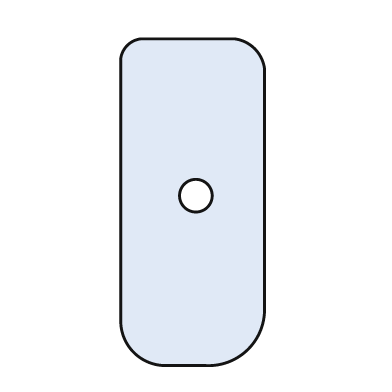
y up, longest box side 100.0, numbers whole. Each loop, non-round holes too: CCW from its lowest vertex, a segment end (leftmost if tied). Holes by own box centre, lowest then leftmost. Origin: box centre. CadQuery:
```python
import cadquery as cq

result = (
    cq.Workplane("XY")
    .moveTo(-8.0, -50.0)
    .lineTo(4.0, -50.0)
    .threePointArc((17.0, -45.0), (22.0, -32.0))
    .lineTo(22.0, 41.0)
    .threePointArc((19.0, 47.0), (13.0, 50.0))
    .lineTo(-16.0, 50.0)
    .threePointArc((-20.0, 48.0), (-22.0, 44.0))
    .lineTo(-22.0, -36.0)
    .threePointArc((-18.0, -46.0), (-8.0, -50.0))
    .close()
    .moveTo(1.0, 2.0)
    .circle(5.0)
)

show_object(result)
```